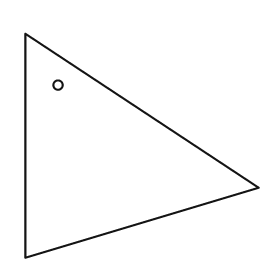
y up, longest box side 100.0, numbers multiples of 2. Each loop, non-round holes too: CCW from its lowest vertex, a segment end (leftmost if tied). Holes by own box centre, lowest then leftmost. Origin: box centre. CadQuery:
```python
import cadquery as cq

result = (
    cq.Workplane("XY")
    .moveTo(-50.0, -48.0)
    .lineTo(50.0, -18.0)
    .lineTo(-50.0, 48.0)
    .close()
    .moveTo(-36.0, 26.0)
    .circle(2.0)
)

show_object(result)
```